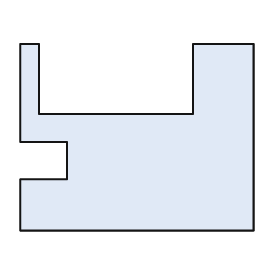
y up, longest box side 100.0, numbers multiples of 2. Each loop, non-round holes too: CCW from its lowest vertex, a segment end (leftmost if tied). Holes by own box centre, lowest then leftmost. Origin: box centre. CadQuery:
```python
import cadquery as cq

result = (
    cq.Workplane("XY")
    .moveTo(-50.0, -40.0)
    .lineTo(50.0, -40.0)
    .lineTo(50.0, 40.0)
    .lineTo(24.0, 40.0)
    .lineTo(24.0, 10.0)
    .lineTo(-42.0, 10.0)
    .lineTo(-42.0, 40.0)
    .lineTo(-50.0, 40.0)
    .lineTo(-50.0, -2.0)
    .lineTo(-30.0, -2.0)
    .lineTo(-30.0, -18.0)
    .lineTo(-50.0, -18.0)
    .close()
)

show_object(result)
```